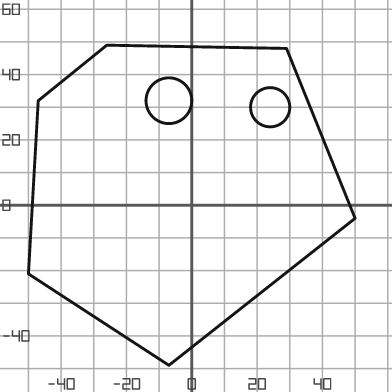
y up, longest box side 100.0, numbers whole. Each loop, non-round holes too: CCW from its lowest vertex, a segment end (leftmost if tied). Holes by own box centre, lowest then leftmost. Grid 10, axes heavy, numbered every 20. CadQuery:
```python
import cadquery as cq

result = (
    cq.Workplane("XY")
    .moveTo(-7.0, -49.0)
    .lineTo(50.0, -4.0)
    .lineTo(29.0, 48.0)
    .lineTo(-26.0, 49.0)
    .lineTo(-47.0, 32.0)
    .lineTo(-50.0, -21.0)
    .close()
    .moveTo(24.0, 30.0)
    .circle(6.0)
    .moveTo(-7.0, 32.0)
    .circle(7.0)
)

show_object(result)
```